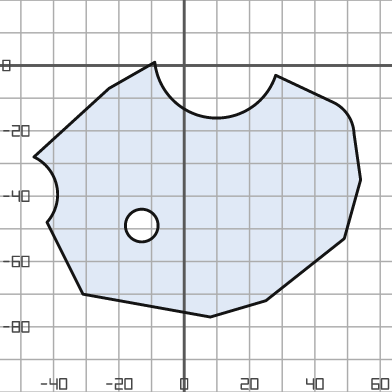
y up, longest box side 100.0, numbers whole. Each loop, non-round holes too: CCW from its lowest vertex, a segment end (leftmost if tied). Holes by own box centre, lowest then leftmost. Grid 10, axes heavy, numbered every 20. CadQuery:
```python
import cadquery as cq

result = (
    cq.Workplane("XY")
    .moveTo(8.0, -77.0)
    .lineTo(25.0, -72.0)
    .lineTo(49.0, -53.0)
    .lineTo(54.0, -35.0)
    .lineTo(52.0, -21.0)
    .threePointArc((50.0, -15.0), (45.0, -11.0))
    .lineTo(28.0, -3.0)
    .threePointArc((8.0, -16.0), (-9.0, 1.0))
    .lineTo(-23.0, -7.0)
    .lineTo(-46.0, -28.0)
    .threePointArc((-39.0, -37.0), (-42.0, -48.0))
    .lineTo(-31.0, -70.0)
    .close()
    .moveTo(-13.0, -49.0)
    .circle(5.0)
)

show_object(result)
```